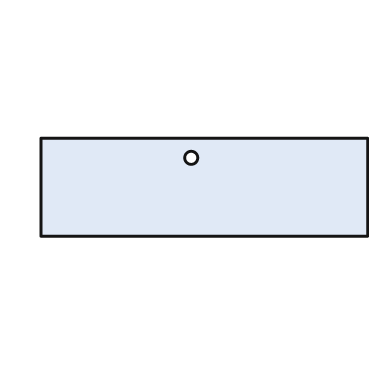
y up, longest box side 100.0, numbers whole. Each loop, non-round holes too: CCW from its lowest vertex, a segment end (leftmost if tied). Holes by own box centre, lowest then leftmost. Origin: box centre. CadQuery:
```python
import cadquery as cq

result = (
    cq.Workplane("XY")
    .moveTo(-50.0, -15.0)
    .lineTo(50.0, -15.0)
    .lineTo(50.0, 15.0)
    .lineTo(-50.0, 15.0)
    .close()
    .moveTo(-4.0, 9.0)
    .circle(2.0)
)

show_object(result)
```